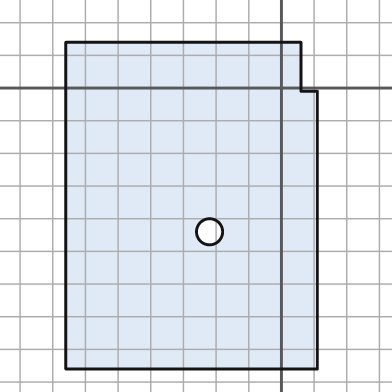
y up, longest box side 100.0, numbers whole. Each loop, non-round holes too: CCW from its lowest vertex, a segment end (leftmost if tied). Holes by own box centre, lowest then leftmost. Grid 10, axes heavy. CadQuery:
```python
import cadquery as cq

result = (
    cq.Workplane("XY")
    .moveTo(-66.0, -86.0)
    .lineTo(11.0, -86.0)
    .lineTo(11.0, -1.0)
    .lineTo(6.0, -1.0)
    .lineTo(6.0, 14.0)
    .lineTo(-66.0, 14.0)
    .close()
    .moveTo(-22.0, -44.0)
    .circle(4.0)
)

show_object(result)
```